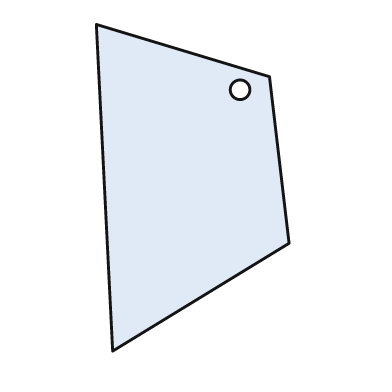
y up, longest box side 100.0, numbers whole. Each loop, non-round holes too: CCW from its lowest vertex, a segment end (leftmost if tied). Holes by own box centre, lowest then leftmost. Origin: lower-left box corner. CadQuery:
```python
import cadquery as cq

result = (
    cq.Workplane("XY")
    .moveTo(5.0, 0.0)
    .lineTo(59.0, 33.0)
    .lineTo(53.0, 84.0)
    .lineTo(0.0, 100.0)
    .close()
    .moveTo(44.0, 80.0)
    .circle(3.0)
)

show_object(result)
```